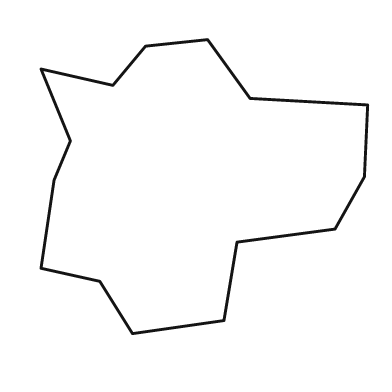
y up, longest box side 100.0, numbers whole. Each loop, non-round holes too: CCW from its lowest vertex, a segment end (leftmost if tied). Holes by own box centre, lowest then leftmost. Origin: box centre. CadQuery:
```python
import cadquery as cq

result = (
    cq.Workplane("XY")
    .moveTo(-22.0, -45.0)
    .lineTo(6.0, -41.0)
    .lineTo(10.0, -17.0)
    .lineTo(40.0, -13.0)
    .lineTo(49.0, 3.0)
    .lineTo(50.0, 25.0)
    .lineTo(14.0, 27.0)
    .lineTo(1.0, 45.0)
    .lineTo(-18.0, 43.0)
    .lineTo(-28.0, 31.0)
    .lineTo(-50.0, 36.0)
    .lineTo(-41.0, 14.0)
    .lineTo(-46.0, 2.0)
    .lineTo(-50.0, -25.0)
    .lineTo(-32.0, -29.0)
    .close()
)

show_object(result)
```